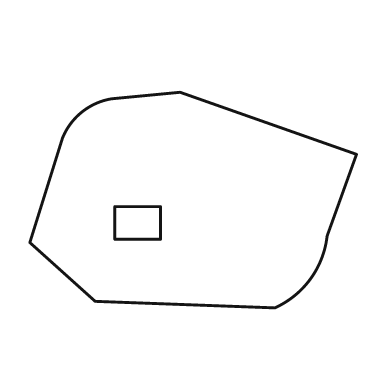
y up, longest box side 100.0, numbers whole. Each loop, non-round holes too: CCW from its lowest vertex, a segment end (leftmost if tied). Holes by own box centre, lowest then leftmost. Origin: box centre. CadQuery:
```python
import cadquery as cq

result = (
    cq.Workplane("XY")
    .moveTo(25.0, -33.0)
    .threePointArc((36.0, -24.0), (41.0, -11.0))
    .lineTo(50.0, 14.0)
    .lineTo(-4.0, 33.0)
    .lineTo(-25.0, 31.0)
    .threePointArc((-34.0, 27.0), (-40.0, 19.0))
    .lineTo(-50.0, -13.0)
    .lineTo(-30.0, -31.0)
    .close()
    .moveTo(-24.0, -12.0)
    .lineTo(-10.0, -12.0)
    .lineTo(-10.0, -2.0)
    .lineTo(-24.0, -2.0)
    .close()
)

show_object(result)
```